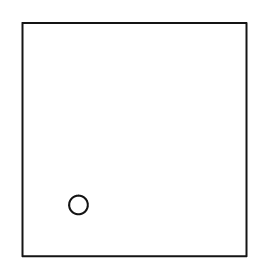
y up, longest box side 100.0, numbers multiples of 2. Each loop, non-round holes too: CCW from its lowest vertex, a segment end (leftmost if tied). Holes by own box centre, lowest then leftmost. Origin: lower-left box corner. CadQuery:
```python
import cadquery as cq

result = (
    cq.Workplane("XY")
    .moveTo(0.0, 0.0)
    .lineTo(96.0, 0.0)
    .lineTo(96.0, 100.0)
    .lineTo(0.0, 100.0)
    .close()
    .moveTo(24.0, 22.0)
    .circle(4.0)
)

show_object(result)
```